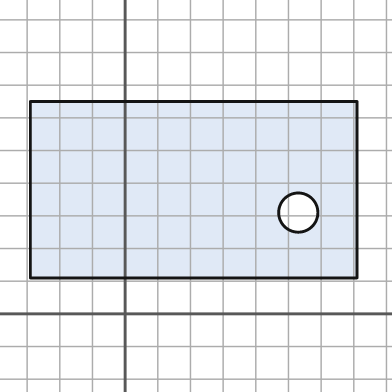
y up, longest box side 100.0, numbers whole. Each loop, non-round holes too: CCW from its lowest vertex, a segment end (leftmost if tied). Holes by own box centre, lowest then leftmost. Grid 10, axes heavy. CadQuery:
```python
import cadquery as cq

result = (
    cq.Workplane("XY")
    .moveTo(-29.0, 11.0)
    .lineTo(71.0, 11.0)
    .lineTo(71.0, 65.0)
    .lineTo(-29.0, 65.0)
    .close()
    .moveTo(53.0, 31.0)
    .circle(6.0)
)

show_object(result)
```